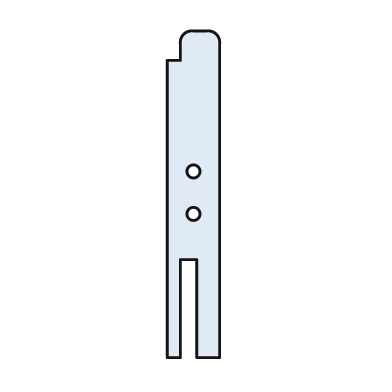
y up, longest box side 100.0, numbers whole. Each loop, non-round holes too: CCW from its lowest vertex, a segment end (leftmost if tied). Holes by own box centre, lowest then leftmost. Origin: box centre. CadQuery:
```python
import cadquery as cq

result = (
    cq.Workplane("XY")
    .moveTo(-8.0, -50.0)
    .lineTo(-4.0, -50.0)
    .lineTo(-4.0, -20.0)
    .lineTo(1.0, -20.0)
    .lineTo(1.0, -50.0)
    .lineTo(8.0, -50.0)
    .lineTo(8.0, 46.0)
    .threePointArc((7.0, 49.0), (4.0, 50.0))
    .lineTo(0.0, 50.0)
    .threePointArc((-3.0, 49.0), (-4.0, 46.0))
    .lineTo(-4.0, 41.0)
    .lineTo(-8.0, 41.0)
    .close()
    .moveTo(0.0, -6.0)
    .circle(2.0)
    .moveTo(0.0, 7.0)
    .circle(2.0)
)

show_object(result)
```